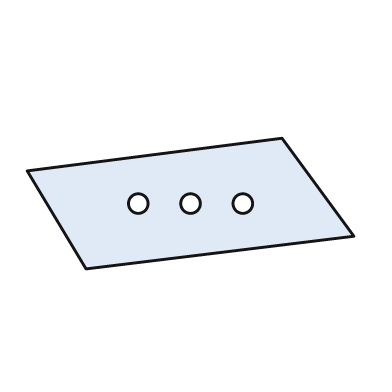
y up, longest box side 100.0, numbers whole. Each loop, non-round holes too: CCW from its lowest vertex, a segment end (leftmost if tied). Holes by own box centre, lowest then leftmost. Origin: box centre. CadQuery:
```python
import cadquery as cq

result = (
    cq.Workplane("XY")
    .moveTo(-32.0, -20.0)
    .lineTo(50.0, -10.0)
    .lineTo(28.0, 20.0)
    .lineTo(-50.0, 10.0)
    .close()
    .moveTo(-16.0, 0.0)
    .circle(3.0)
    .moveTo(0.0, 0.0)
    .circle(3.0)
    .moveTo(16.0, 0.0)
    .circle(3.0)
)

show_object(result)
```